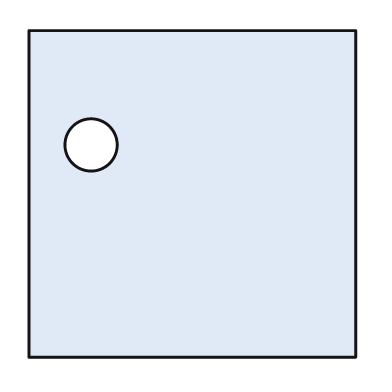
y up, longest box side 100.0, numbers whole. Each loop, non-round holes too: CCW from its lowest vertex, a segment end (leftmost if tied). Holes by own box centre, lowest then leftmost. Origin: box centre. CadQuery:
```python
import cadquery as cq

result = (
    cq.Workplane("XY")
    .moveTo(-50.0, -50.0)
    .lineTo(50.0, -50.0)
    .lineTo(50.0, 50.0)
    .lineTo(-50.0, 50.0)
    .close()
    .moveTo(-31.0, 15.0)
    .circle(8.0)
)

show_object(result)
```